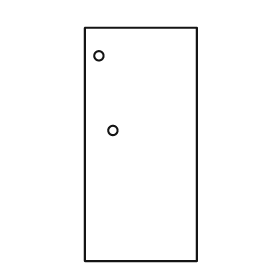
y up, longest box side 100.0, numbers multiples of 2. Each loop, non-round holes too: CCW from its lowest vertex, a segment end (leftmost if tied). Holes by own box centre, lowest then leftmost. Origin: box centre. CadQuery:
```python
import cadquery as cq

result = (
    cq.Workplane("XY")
    .moveTo(-24.0, -50.0)
    .lineTo(24.0, -50.0)
    .lineTo(24.0, 50.0)
    .lineTo(-24.0, 50.0)
    .close()
    .moveTo(-12.0, 6.0)
    .circle(2.0)
    .moveTo(-18.0, 38.0)
    .circle(2.0)
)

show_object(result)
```